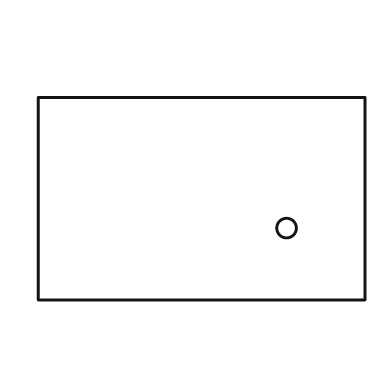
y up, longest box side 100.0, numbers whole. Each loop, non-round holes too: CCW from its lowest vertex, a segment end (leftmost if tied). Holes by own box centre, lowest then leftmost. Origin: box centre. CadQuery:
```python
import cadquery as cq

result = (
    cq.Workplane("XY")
    .moveTo(-50.0, -31.0)
    .lineTo(50.0, -31.0)
    .lineTo(50.0, 31.0)
    .lineTo(-50.0, 31.0)
    .close()
    .moveTo(26.0, -9.0)
    .circle(3.0)
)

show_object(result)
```